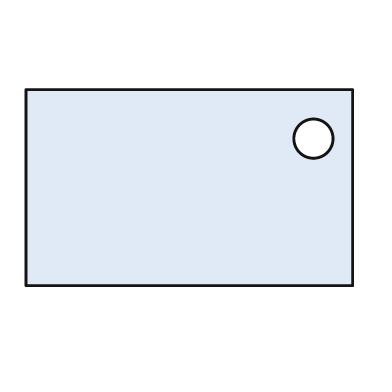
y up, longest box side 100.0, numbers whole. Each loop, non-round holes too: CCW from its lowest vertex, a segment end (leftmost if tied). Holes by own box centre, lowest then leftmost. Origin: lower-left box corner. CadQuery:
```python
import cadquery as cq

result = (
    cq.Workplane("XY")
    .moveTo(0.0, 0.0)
    .lineTo(100.0, 0.0)
    .lineTo(100.0, 60.0)
    .lineTo(0.0, 60.0)
    .close()
    .moveTo(88.0, 45.0)
    .circle(6.0)
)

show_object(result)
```